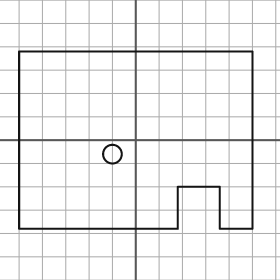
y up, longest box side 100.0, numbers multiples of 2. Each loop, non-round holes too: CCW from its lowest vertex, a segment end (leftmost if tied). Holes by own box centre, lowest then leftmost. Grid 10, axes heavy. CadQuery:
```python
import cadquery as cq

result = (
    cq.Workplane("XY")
    .moveTo(-50.0, -38.0)
    .lineTo(18.0, -38.0)
    .lineTo(18.0, -20.0)
    .lineTo(36.0, -20.0)
    .lineTo(36.0, -38.0)
    .lineTo(50.0, -38.0)
    .lineTo(50.0, 38.0)
    .lineTo(-50.0, 38.0)
    .close()
    .moveTo(-10.0, -6.0)
    .circle(4.0)
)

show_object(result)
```